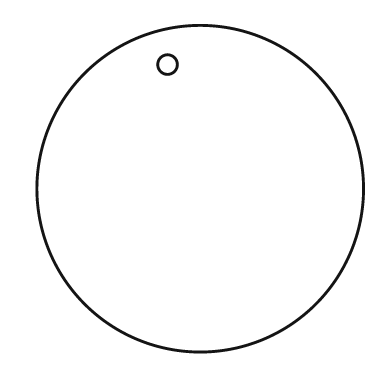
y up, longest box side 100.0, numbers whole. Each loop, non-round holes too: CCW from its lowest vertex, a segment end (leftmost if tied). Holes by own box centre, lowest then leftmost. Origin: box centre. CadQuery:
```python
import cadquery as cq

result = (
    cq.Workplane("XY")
    .moveTo(0.0, 0.0)
    .circle(50.0)
    .moveTo(-10.0, 38.0)
    .circle(3.0)
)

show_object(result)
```